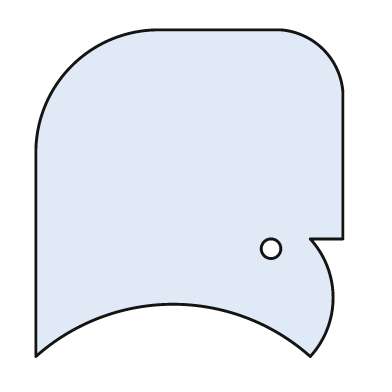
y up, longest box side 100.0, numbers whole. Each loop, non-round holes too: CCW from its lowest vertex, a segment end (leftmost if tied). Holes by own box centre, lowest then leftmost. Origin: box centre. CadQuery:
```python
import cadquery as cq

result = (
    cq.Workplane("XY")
    .moveTo(-47.0, -50.0)
    .threePointArc((-5.0, -34.0), (37.0, -50.0))
    .threePointArc((44.0, -32.0), (37.0, -14.0))
    .lineTo(47.0, -14.0)
    .lineTo(47.0, 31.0)
    .threePointArc((41.0, 44.0), (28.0, 50.0))
    .lineTo(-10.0, 50.0)
    .threePointArc((-36.0, 39.0), (-47.0, 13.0))
    .close()
    .moveTo(25.0, -17.0)
    .circle(3.0)
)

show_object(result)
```